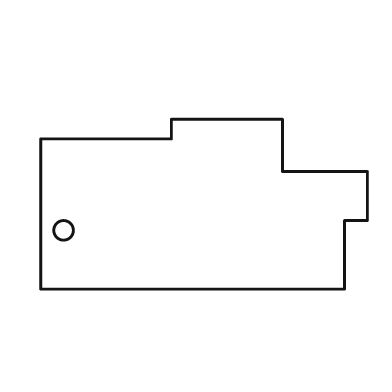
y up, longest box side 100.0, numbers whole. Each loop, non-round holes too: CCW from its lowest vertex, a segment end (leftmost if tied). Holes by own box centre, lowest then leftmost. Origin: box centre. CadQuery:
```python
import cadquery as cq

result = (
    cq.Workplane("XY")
    .moveTo(-50.0, -26.0)
    .lineTo(43.0, -26.0)
    .lineTo(43.0, -5.0)
    .lineTo(50.0, -5.0)
    .lineTo(50.0, 10.0)
    .lineTo(24.0, 10.0)
    .lineTo(24.0, 26.0)
    .lineTo(-10.0, 26.0)
    .lineTo(-10.0, 20.0)
    .lineTo(-50.0, 20.0)
    .close()
    .moveTo(-43.0, -8.0)
    .circle(3.0)
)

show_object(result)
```